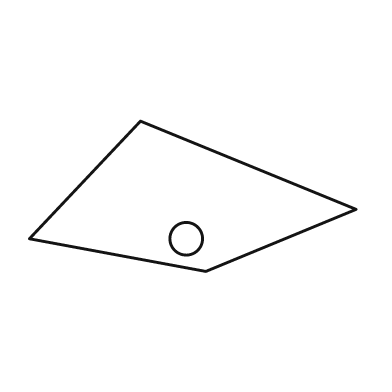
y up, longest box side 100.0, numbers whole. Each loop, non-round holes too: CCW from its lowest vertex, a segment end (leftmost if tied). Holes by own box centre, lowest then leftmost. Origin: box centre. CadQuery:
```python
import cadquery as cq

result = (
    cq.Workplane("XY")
    .moveTo(4.0, -23.0)
    .lineTo(50.0, -4.0)
    .lineTo(-16.0, 23.0)
    .lineTo(-50.0, -13.0)
    .close()
    .moveTo(-2.0, -13.0)
    .circle(5.0)
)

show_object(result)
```